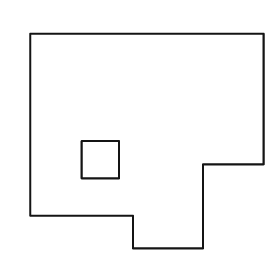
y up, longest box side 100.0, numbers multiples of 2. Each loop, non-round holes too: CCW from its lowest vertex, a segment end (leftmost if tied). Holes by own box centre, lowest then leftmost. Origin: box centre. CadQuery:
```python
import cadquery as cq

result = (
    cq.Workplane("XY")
    .moveTo(-6.0, -46.0)
    .lineTo(24.0, -46.0)
    .lineTo(24.0, -10.0)
    .lineTo(50.0, -10.0)
    .lineTo(50.0, 46.0)
    .lineTo(-50.0, 46.0)
    .lineTo(-50.0, -32.0)
    .lineTo(-6.0, -32.0)
    .close()
    .moveTo(-28.0, -16.0)
    .lineTo(-12.0, -16.0)
    .lineTo(-12.0, 0.0)
    .lineTo(-28.0, 0.0)
    .close()
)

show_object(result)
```